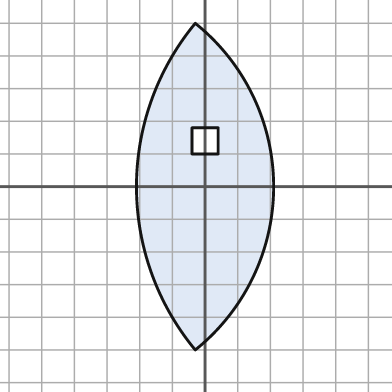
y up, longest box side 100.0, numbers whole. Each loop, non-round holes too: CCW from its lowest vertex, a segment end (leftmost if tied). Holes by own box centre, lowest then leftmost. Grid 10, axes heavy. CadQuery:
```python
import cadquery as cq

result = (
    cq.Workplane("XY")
    .moveTo(-3.0, -50.0)
    .threePointArc((21.0, 0.0), (-3.0, 50.0))
    .threePointArc((-21.0, 0.0), (-3.0, -50.0))
    .close()
    .moveTo(-4.0, 10.0)
    .lineTo(4.0, 10.0)
    .lineTo(4.0, 18.0)
    .lineTo(-4.0, 18.0)
    .close()
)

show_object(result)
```